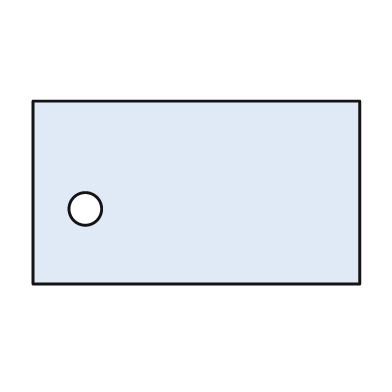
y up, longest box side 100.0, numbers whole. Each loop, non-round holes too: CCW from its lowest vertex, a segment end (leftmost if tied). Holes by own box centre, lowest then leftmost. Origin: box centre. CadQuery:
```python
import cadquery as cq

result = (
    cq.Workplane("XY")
    .moveTo(-50.0, -28.0)
    .lineTo(50.0, -28.0)
    .lineTo(50.0, 28.0)
    .lineTo(-50.0, 28.0)
    .close()
    .moveTo(-34.0, -5.0)
    .circle(5.0)
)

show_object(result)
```